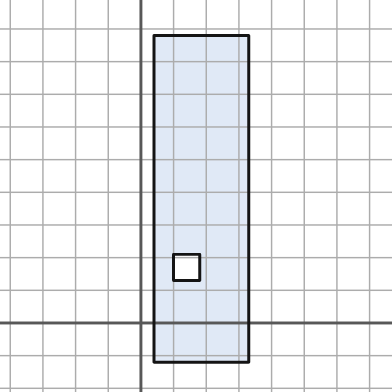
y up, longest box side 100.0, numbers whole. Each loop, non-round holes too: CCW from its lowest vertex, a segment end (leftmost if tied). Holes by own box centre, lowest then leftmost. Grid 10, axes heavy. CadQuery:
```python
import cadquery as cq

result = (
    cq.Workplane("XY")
    .moveTo(4.0, -12.0)
    .lineTo(33.0, -12.0)
    .lineTo(33.0, 88.0)
    .lineTo(4.0, 88.0)
    .close()
    .moveTo(10.0, 13.0)
    .lineTo(18.0, 13.0)
    .lineTo(18.0, 21.0)
    .lineTo(10.0, 21.0)
    .close()
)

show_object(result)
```